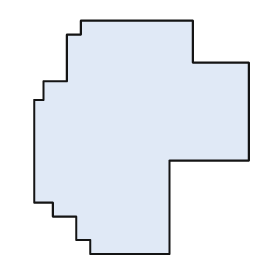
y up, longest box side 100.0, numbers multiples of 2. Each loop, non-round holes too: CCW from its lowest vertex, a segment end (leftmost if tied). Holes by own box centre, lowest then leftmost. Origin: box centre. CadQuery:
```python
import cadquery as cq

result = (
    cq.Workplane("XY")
    .moveTo(-22.0, -50.0)
    .lineTo(12.0, -50.0)
    .lineTo(12.0, -10.0)
    .lineTo(46.0, -10.0)
    .lineTo(46.0, 32.0)
    .lineTo(22.0, 32.0)
    .lineTo(22.0, 50.0)
    .lineTo(-26.0, 50.0)
    .lineTo(-26.0, 44.0)
    .lineTo(-32.0, 44.0)
    .lineTo(-32.0, 24.0)
    .lineTo(-42.0, 24.0)
    .lineTo(-42.0, 16.0)
    .lineTo(-46.0, 16.0)
    .lineTo(-46.0, -28.0)
    .lineTo(-38.0, -28.0)
    .lineTo(-38.0, -34.0)
    .lineTo(-28.0, -34.0)
    .lineTo(-28.0, -44.0)
    .lineTo(-22.0, -44.0)
    .close()
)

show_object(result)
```